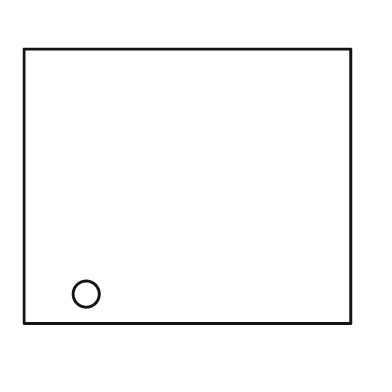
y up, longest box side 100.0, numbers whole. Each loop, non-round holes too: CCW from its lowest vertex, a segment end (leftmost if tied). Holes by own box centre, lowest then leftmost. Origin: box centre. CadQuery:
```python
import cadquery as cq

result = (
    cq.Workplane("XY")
    .moveTo(-50.0, -42.0)
    .lineTo(50.0, -42.0)
    .lineTo(50.0, 42.0)
    .lineTo(-50.0, 42.0)
    .close()
    .moveTo(-31.0, -33.0)
    .circle(4.0)
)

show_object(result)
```